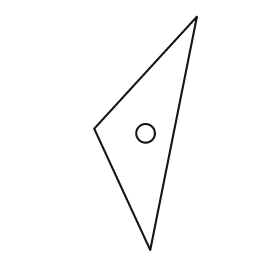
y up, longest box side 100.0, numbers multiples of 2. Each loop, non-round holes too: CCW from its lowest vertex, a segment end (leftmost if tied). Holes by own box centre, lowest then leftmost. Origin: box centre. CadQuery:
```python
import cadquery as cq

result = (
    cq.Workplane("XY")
    .moveTo(2.0, -50.0)
    .lineTo(22.0, 50.0)
    .lineTo(-22.0, 2.0)
    .close()
    .moveTo(0.0, 0.0)
    .circle(4.0)
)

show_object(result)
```